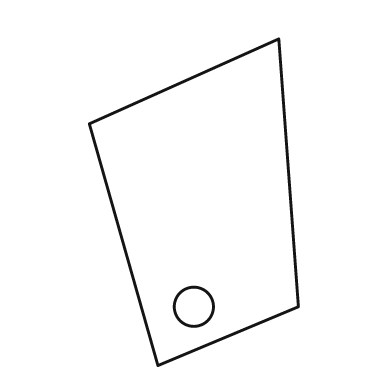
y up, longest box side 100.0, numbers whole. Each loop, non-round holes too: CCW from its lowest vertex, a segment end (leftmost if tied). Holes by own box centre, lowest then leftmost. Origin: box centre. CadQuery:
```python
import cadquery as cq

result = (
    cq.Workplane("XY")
    .moveTo(-11.0, -50.0)
    .lineTo(32.0, -32.0)
    .lineTo(26.0, 50.0)
    .lineTo(-32.0, 24.0)
    .close()
    .moveTo(0.0, -32.0)
    .circle(6.0)
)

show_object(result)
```